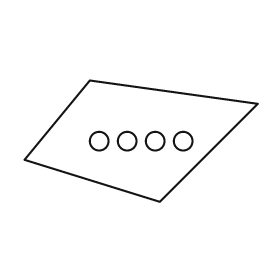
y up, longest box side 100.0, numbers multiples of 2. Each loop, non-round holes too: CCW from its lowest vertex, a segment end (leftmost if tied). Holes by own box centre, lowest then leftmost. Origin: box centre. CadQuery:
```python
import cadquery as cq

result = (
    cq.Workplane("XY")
    .moveTo(8.0, -26.0)
    .lineTo(50.0, 16.0)
    .lineTo(-22.0, 26.0)
    .lineTo(-50.0, -8.0)
    .close()
    .moveTo(-18.0, 0.0)
    .circle(4.0)
    .moveTo(-6.0, 0.0)
    .circle(4.0)
    .moveTo(6.0, 0.0)
    .circle(4.0)
    .moveTo(18.0, 0.0)
    .circle(4.0)
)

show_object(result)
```